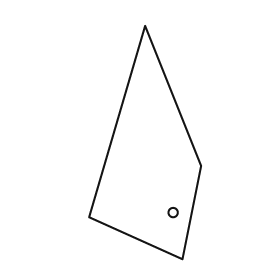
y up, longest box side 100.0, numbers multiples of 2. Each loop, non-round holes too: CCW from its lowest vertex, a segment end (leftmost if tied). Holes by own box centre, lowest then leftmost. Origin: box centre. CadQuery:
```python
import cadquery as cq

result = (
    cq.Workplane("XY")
    .moveTo(16.0, -50.0)
    .lineTo(24.0, -10.0)
    .lineTo(0.0, 50.0)
    .lineTo(-24.0, -32.0)
    .close()
    .moveTo(12.0, -30.0)
    .circle(2.0)
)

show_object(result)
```